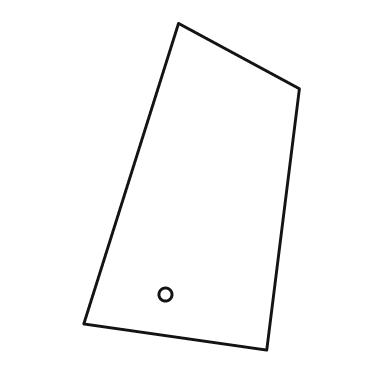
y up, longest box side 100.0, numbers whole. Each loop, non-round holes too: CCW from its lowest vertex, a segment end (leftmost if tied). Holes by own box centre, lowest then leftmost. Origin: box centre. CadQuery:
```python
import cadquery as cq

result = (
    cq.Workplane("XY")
    .moveTo(23.0, -50.0)
    .lineTo(33.0, 30.0)
    .lineTo(-4.0, 50.0)
    .lineTo(-33.0, -42.0)
    .close()
    .moveTo(-8.0, -33.0)
    .circle(2.0)
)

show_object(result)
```